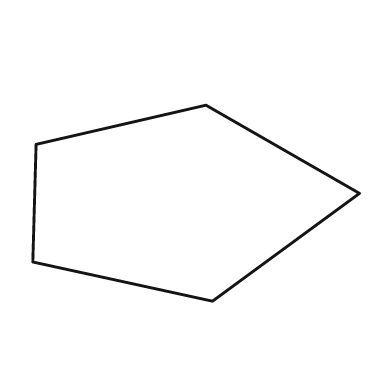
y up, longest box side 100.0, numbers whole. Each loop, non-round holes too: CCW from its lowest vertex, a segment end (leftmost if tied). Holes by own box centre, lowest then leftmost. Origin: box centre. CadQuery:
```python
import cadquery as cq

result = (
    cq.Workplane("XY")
    .moveTo(5.0, -30.0)
    .lineTo(50.0, 3.0)
    .lineTo(3.0, 30.0)
    .lineTo(-49.0, 18.0)
    .lineTo(-50.0, -18.0)
    .close()
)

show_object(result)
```